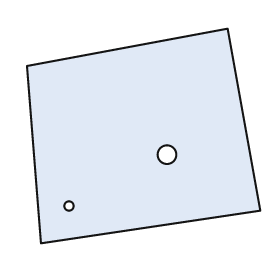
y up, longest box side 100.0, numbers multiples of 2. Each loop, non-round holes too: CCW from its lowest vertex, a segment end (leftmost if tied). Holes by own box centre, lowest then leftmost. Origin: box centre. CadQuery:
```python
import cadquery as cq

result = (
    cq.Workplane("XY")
    .moveTo(-44.0, -46.0)
    .lineTo(50.0, -32.0)
    .lineTo(36.0, 46.0)
    .lineTo(-50.0, 30.0)
    .close()
    .moveTo(-32.0, -30.0)
    .circle(2.0)
    .moveTo(10.0, -8.0)
    .circle(4.0)
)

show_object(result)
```